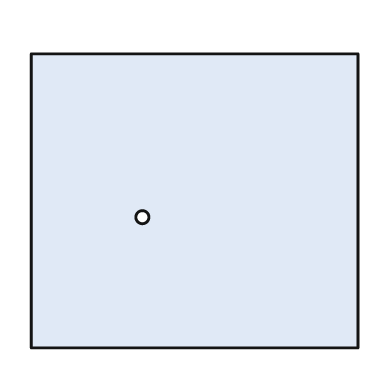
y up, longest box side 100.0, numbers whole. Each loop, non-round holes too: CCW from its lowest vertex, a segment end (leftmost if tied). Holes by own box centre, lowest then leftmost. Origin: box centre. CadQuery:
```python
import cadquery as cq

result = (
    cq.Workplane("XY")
    .moveTo(-50.0, -45.0)
    .lineTo(50.0, -45.0)
    .lineTo(50.0, 45.0)
    .lineTo(-50.0, 45.0)
    .close()
    .moveTo(-16.0, -5.0)
    .circle(2.0)
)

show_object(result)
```